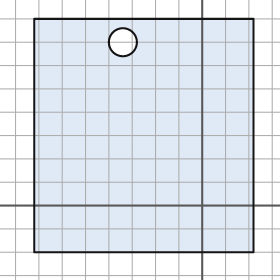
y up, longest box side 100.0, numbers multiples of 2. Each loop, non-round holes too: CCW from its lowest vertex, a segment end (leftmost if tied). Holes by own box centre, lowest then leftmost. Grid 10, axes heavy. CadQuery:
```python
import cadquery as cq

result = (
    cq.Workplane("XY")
    .moveTo(-72.0, -20.0)
    .lineTo(22.0, -20.0)
    .lineTo(22.0, 80.0)
    .lineTo(-72.0, 80.0)
    .close()
    .moveTo(-34.0, 70.0)
    .circle(6.0)
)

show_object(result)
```